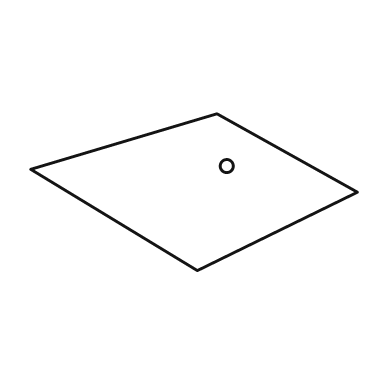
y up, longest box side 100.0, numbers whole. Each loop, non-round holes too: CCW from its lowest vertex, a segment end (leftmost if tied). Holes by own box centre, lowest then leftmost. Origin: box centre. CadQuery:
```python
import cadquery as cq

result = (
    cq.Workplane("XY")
    .moveTo(1.0, -24.0)
    .lineTo(50.0, 0.0)
    .lineTo(7.0, 24.0)
    .lineTo(-50.0, 7.0)
    .close()
    .moveTo(10.0, 8.0)
    .circle(2.0)
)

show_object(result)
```